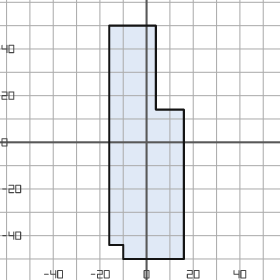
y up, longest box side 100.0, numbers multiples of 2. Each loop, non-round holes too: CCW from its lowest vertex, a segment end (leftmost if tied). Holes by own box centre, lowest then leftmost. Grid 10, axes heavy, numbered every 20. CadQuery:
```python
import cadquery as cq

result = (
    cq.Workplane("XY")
    .moveTo(-10.0, -50.0)
    .lineTo(16.0, -50.0)
    .lineTo(16.0, 14.0)
    .lineTo(4.0, 14.0)
    .lineTo(4.0, 50.0)
    .lineTo(-16.0, 50.0)
    .lineTo(-16.0, -44.0)
    .lineTo(-10.0, -44.0)
    .close()
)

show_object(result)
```